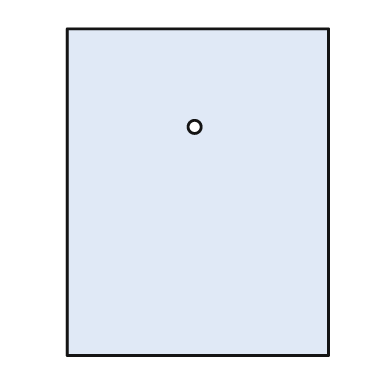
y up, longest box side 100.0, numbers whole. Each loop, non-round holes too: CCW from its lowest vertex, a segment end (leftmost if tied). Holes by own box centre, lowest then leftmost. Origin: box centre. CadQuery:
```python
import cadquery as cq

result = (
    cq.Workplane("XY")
    .moveTo(-40.0, -50.0)
    .lineTo(40.0, -50.0)
    .lineTo(40.0, 50.0)
    .lineTo(-40.0, 50.0)
    .close()
    .moveTo(-1.0, 20.0)
    .circle(2.0)
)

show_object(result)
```